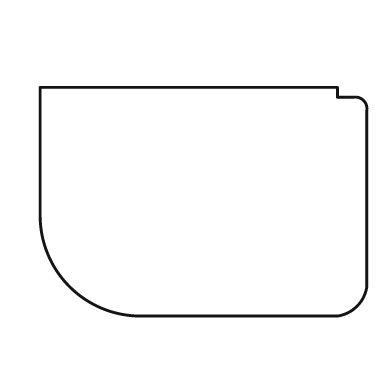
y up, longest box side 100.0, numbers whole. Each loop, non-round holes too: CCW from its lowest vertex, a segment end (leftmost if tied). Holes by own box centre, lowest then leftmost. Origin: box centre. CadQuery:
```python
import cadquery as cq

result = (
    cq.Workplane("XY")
    .moveTo(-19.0, -35.0)
    .lineTo(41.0, -35.0)
    .threePointArc((47.0, -32.0), (50.0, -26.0))
    .lineTo(50.0, 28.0)
    .threePointArc((49.0, 31.0), (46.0, 32.0))
    .lineTo(41.0, 32.0)
    .lineTo(41.0, 35.0)
    .lineTo(-50.0, 35.0)
    .lineTo(-50.0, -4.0)
    .threePointArc((-41.0, -26.0), (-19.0, -35.0))
    .close()
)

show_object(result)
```